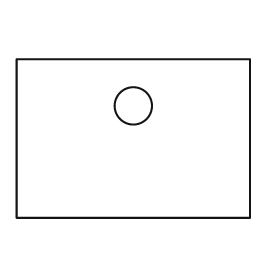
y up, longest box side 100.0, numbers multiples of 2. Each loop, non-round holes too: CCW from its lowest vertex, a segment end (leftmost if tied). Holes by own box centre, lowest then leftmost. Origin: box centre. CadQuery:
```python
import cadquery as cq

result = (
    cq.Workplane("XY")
    .moveTo(-50.0, -34.0)
    .lineTo(50.0, -34.0)
    .lineTo(50.0, 34.0)
    .lineTo(-50.0, 34.0)
    .close()
    .moveTo(0.0, 14.0)
    .circle(8.0)
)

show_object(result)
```